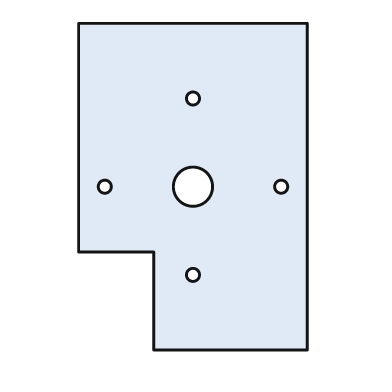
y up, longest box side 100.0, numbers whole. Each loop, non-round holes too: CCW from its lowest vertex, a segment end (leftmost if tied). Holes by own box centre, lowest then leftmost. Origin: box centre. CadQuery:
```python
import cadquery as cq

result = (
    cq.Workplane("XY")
    .moveTo(-12.0, -50.0)
    .lineTo(35.0, -50.0)
    .lineTo(35.0, 50.0)
    .lineTo(-35.0, 50.0)
    .lineTo(-35.0, -20.0)
    .lineTo(-12.0, -20.0)
    .close()
    .moveTo(0.0, -27.0)
    .circle(2.0)
    .moveTo(-27.0, 0.0)
    .circle(2.0)
    .moveTo(0.0, 0.0)
    .circle(6.0)
    .moveTo(27.0, 0.0)
    .circle(2.0)
    .moveTo(0.0, 27.0)
    .circle(2.0)
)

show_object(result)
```